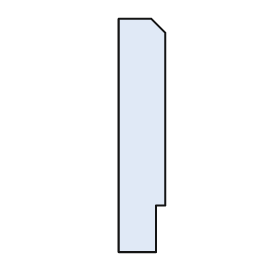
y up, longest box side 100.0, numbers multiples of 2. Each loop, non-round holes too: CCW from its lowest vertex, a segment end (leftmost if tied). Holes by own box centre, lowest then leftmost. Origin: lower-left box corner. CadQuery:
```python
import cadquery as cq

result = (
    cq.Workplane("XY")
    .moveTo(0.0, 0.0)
    .lineTo(16.0, 0.0)
    .lineTo(16.0, 20.0)
    .lineTo(20.0, 20.0)
    .lineTo(20.0, 94.0)
    .lineTo(14.0, 100.0)
    .lineTo(0.0, 100.0)
    .close()
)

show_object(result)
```